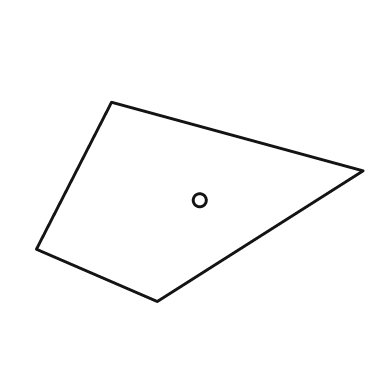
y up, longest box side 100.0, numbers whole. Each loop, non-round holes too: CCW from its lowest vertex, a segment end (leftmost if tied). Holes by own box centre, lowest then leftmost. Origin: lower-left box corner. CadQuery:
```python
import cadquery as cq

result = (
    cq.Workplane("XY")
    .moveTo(37.0, 0.0)
    .lineTo(100.0, 40.0)
    .lineTo(23.0, 61.0)
    .lineTo(0.0, 16.0)
    .close()
    .moveTo(50.0, 31.0)
    .circle(2.0)
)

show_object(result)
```